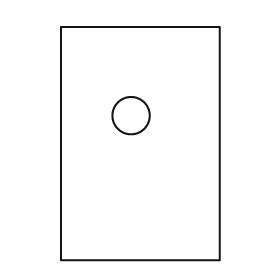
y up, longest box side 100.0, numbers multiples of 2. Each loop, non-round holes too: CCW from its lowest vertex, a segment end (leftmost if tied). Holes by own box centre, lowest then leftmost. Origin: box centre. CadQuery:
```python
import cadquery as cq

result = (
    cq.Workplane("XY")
    .moveTo(-34.0, -50.0)
    .lineTo(34.0, -50.0)
    .lineTo(34.0, 50.0)
    .lineTo(-34.0, 50.0)
    .close()
    .moveTo(-4.0, 12.0)
    .circle(8.0)
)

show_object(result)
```